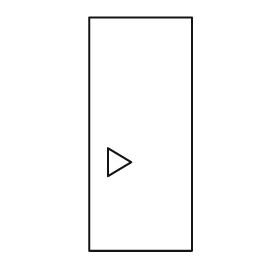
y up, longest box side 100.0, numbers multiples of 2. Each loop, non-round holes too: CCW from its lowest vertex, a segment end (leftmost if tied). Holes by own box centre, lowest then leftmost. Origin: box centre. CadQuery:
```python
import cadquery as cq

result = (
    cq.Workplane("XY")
    .moveTo(-22.0, -50.0)
    .lineTo(22.0, -50.0)
    .lineTo(22.0, 50.0)
    .lineTo(-22.0, 50.0)
    .close()
    .moveTo(-14.0, -18.0)
    .lineTo(-4.0, -12.0)
    .lineTo(-14.0, -6.0)
    .close()
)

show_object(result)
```